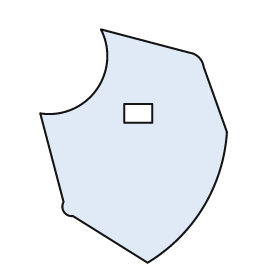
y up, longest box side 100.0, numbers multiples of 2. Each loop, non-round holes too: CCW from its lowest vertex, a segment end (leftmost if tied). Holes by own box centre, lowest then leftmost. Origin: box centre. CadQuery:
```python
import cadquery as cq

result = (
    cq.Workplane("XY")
    .moveTo(6.0, -50.0)
    .threePointArc((30.0, -26.0), (40.0, 6.0))
    .lineTo(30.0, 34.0)
    .threePointArc((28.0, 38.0), (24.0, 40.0))
    .lineTo(-14.0, 50.0)
    .threePointArc((-16.0, 24.0), (-40.0, 14.0))
    .lineTo(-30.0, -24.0)
    .threePointArc((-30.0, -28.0), (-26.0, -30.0))
    .close()
    .moveTo(-4.0, 10.0)
    .lineTo(8.0, 10.0)
    .lineTo(8.0, 18.0)
    .lineTo(-4.0, 18.0)
    .close()
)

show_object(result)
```